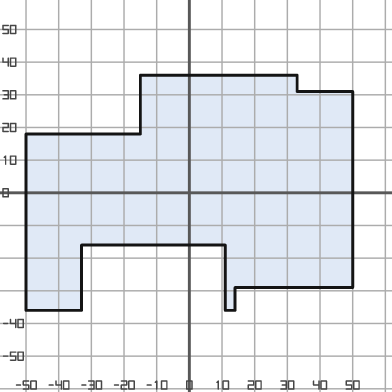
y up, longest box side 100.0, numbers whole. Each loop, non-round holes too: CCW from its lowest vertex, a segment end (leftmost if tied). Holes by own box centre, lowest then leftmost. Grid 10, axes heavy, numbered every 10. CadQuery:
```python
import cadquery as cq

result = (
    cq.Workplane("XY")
    .moveTo(-50.0, -36.0)
    .lineTo(-33.0, -36.0)
    .lineTo(-33.0, -16.0)
    .lineTo(11.0, -16.0)
    .lineTo(11.0, -36.0)
    .lineTo(14.0, -36.0)
    .lineTo(14.0, -29.0)
    .lineTo(50.0, -29.0)
    .lineTo(50.0, 31.0)
    .lineTo(33.0, 31.0)
    .lineTo(33.0, 36.0)
    .lineTo(-15.0, 36.0)
    .lineTo(-15.0, 18.0)
    .lineTo(-50.0, 18.0)
    .close()
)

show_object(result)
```